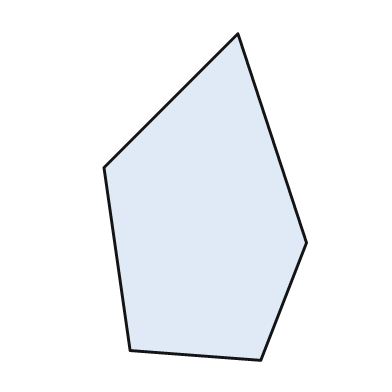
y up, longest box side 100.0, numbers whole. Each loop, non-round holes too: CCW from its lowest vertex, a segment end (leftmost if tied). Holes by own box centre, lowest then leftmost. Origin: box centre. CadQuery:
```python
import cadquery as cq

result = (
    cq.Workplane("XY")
    .moveTo(17.0, -50.0)
    .lineTo(31.0, -14.0)
    .lineTo(10.0, 50.0)
    .lineTo(-31.0, 9.0)
    .lineTo(-23.0, -47.0)
    .close()
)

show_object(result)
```